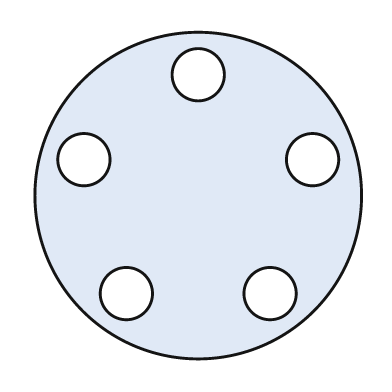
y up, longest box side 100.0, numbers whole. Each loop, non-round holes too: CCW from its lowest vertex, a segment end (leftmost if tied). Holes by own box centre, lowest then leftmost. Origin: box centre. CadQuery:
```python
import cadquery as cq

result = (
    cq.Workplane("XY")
    .moveTo(0.0, 0.0)
    .circle(50.0)
    .moveTo(-22.0, -30.0)
    .circle(8.0)
    .moveTo(22.0, -30.0)
    .circle(8.0)
    .moveTo(-35.0, 11.0)
    .circle(8.0)
    .moveTo(35.0, 11.0)
    .circle(8.0)
    .moveTo(0.0, 37.0)
    .circle(8.0)
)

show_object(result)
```